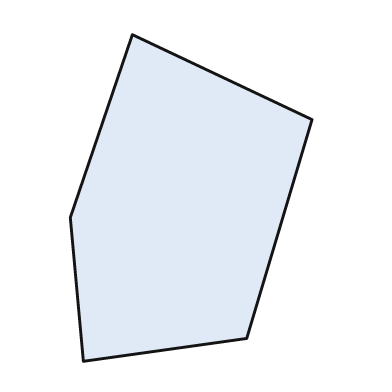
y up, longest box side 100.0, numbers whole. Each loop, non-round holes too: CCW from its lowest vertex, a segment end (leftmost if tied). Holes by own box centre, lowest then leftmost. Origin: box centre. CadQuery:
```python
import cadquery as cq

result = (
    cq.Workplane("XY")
    .moveTo(-33.0, -50.0)
    .lineTo(17.0, -43.0)
    .lineTo(37.0, 24.0)
    .lineTo(-18.0, 50.0)
    .lineTo(-37.0, -6.0)
    .close()
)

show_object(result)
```